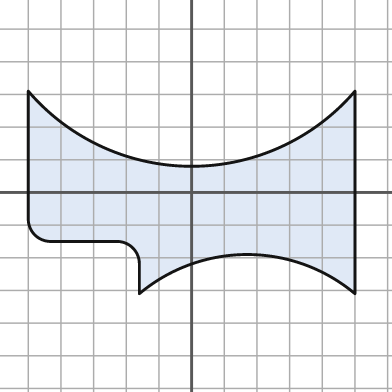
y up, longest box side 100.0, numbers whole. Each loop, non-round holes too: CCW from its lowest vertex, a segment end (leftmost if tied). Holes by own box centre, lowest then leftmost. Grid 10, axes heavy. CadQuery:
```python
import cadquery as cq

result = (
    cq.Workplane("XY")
    .moveTo(-16.0, -31.0)
    .threePointArc((17.0, -19.0), (50.0, -31.0))
    .lineTo(50.0, 31.0)
    .threePointArc((0.0, 8.0), (-50.0, 31.0))
    .lineTo(-50.0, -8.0)
    .threePointArc((-48.0, -13.0), (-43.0, -15.0))
    .lineTo(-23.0, -15.0)
    .threePointArc((-18.0, -17.0), (-16.0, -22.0))
    .close()
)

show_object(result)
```